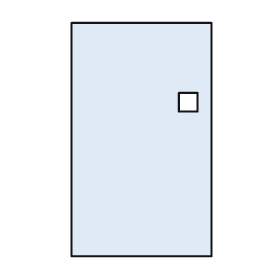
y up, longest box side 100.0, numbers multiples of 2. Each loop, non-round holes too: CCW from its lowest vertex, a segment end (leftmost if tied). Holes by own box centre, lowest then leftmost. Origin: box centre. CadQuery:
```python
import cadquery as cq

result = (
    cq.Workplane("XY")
    .moveTo(-30.0, -50.0)
    .lineTo(30.0, -50.0)
    .lineTo(30.0, 50.0)
    .lineTo(-30.0, 50.0)
    .close()
    .moveTo(16.0, 12.0)
    .lineTo(24.0, 12.0)
    .lineTo(24.0, 20.0)
    .lineTo(16.0, 20.0)
    .close()
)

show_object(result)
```